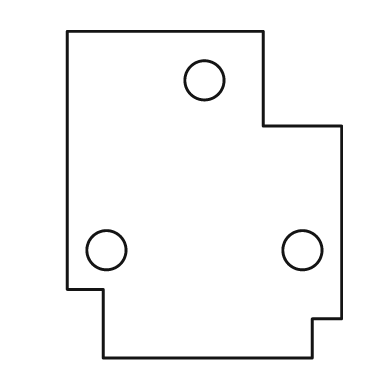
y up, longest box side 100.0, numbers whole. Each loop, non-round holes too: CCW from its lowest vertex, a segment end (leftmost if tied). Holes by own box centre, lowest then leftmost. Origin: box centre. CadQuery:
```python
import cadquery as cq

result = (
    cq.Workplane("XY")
    .moveTo(-31.0, -50.0)
    .lineTo(33.0, -50.0)
    .lineTo(33.0, -38.0)
    .lineTo(42.0, -38.0)
    .lineTo(42.0, 21.0)
    .lineTo(18.0, 21.0)
    .lineTo(18.0, 50.0)
    .lineTo(-42.0, 50.0)
    .lineTo(-42.0, -29.0)
    .lineTo(-31.0, -29.0)
    .close()
    .moveTo(-30.0, -17.0)
    .circle(6.0)
    .moveTo(30.0, -17.0)
    .circle(6.0)
    .moveTo(0.0, 35.0)
    .circle(6.0)
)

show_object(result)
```